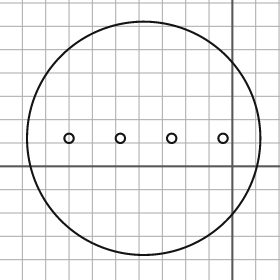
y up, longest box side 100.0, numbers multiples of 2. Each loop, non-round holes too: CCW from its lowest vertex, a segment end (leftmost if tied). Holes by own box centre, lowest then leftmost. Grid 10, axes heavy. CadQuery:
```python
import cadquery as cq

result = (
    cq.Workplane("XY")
    .moveTo(-38.0, 12.0)
    .circle(50.0)
    .moveTo(-70.0, 12.0)
    .circle(2.0)
    .moveTo(-48.0, 12.0)
    .circle(2.0)
    .moveTo(-26.0, 12.0)
    .circle(2.0)
    .moveTo(-4.0, 12.0)
    .circle(2.0)
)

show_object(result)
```